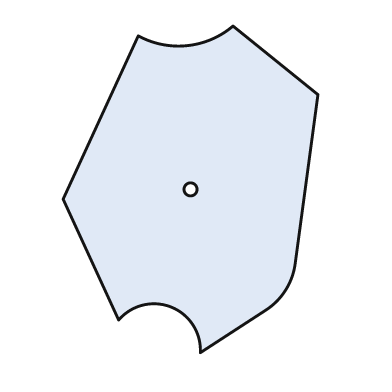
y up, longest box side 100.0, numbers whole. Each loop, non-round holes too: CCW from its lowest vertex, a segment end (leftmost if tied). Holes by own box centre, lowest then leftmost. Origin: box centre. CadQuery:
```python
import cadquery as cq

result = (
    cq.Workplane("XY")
    .moveTo(3.0, -50.0)
    .lineTo(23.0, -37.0)
    .threePointArc((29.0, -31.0), (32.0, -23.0))
    .lineTo(39.0, 29.0)
    .lineTo(13.0, 50.0)
    .threePointArc((-1.0, 44.0), (-16.0, 47.0))
    .lineTo(-39.0, -3.0)
    .lineTo(-22.0, -40.0)
    .threePointArc((-6.0, -36.0), (3.0, -50.0))
    .close()
    .moveTo(0.0, 0.0)
    .circle(2.0)
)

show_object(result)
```